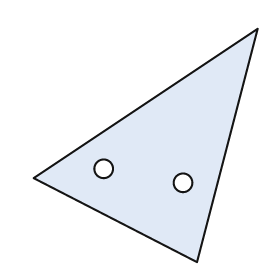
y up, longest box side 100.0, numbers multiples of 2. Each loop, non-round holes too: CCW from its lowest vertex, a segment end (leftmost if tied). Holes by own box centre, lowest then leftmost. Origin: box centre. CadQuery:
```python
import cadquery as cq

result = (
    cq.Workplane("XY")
    .moveTo(22.0, -50.0)
    .lineTo(48.0, 50.0)
    .lineTo(-48.0, -14.0)
    .close()
    .moveTo(16.0, -16.0)
    .circle(4.0)
    .moveTo(-18.0, -10.0)
    .circle(4.0)
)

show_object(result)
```